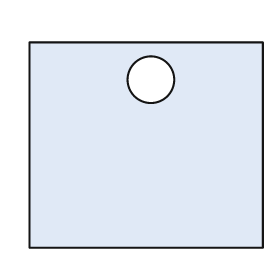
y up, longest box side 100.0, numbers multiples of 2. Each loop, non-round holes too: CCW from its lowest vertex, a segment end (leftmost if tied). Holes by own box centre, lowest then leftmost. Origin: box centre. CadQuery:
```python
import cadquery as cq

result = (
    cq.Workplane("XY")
    .moveTo(-50.0, -44.0)
    .lineTo(50.0, -44.0)
    .lineTo(50.0, 44.0)
    .lineTo(-50.0, 44.0)
    .close()
    .moveTo(2.0, 28.0)
    .circle(10.0)
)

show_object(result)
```